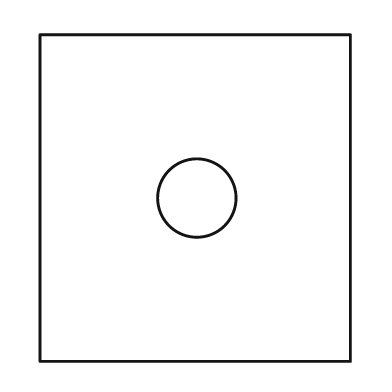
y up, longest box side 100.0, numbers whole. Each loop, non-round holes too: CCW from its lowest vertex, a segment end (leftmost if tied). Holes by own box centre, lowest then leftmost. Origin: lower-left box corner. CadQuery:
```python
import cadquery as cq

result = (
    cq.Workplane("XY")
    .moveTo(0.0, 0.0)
    .lineTo(95.0, 0.0)
    .lineTo(95.0, 100.0)
    .lineTo(0.0, 100.0)
    .close()
    .moveTo(48.0, 50.0)
    .circle(12.0)
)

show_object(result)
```